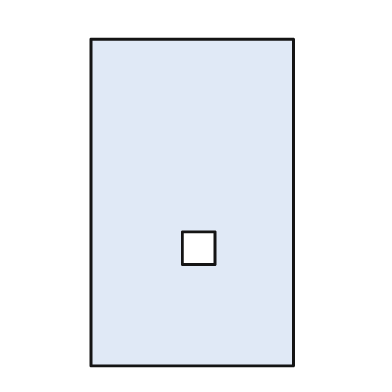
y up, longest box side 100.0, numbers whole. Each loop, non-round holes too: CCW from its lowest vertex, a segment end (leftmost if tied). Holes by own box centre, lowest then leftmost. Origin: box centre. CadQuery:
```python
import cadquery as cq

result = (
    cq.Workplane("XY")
    .moveTo(-31.0, -50.0)
    .lineTo(31.0, -50.0)
    .lineTo(31.0, 50.0)
    .lineTo(-31.0, 50.0)
    .close()
    .moveTo(-3.0, -19.0)
    .lineTo(7.0, -19.0)
    .lineTo(7.0, -9.0)
    .lineTo(-3.0, -9.0)
    .close()
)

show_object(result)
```